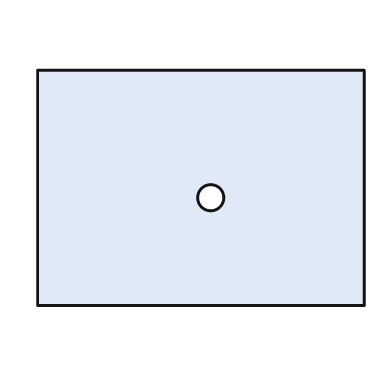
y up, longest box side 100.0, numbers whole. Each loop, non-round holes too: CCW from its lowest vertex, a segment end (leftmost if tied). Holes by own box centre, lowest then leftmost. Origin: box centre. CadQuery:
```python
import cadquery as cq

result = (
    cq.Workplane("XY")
    .moveTo(-50.0, -36.0)
    .lineTo(50.0, -36.0)
    .lineTo(50.0, 36.0)
    .lineTo(-50.0, 36.0)
    .close()
    .moveTo(3.0, -3.0)
    .circle(4.0)
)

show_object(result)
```